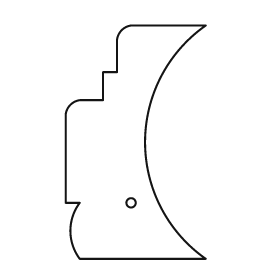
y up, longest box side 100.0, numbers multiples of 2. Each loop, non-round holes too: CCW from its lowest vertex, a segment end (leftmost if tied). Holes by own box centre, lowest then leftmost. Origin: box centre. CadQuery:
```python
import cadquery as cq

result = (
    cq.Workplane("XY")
    .moveTo(-24.0, -50.0)
    .lineTo(30.0, -50.0)
    .threePointArc((4.0, 0.0), (30.0, 50.0))
    .lineTo(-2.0, 50.0)
    .threePointArc((-6.0, 48.0), (-8.0, 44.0))
    .lineTo(-8.0, 30.0)
    .lineTo(-14.0, 30.0)
    .lineTo(-14.0, 18.0)
    .lineTo(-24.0, 18.0)
    .threePointArc((-28.0, 16.0), (-30.0, 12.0))
    .lineTo(-30.0, -26.0)
    .lineTo(-24.0, -26.0)
    .threePointArc((-28.0, -38.0), (-24.0, -50.0))
    .close()
    .moveTo(-2.0, -26.0)
    .circle(2.0)
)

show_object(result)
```